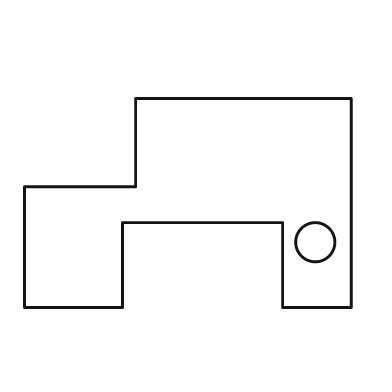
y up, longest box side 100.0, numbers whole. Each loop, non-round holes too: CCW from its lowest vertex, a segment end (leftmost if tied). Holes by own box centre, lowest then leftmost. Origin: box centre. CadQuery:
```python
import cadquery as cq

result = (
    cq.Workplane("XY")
    .moveTo(-50.0, -32.0)
    .lineTo(-20.0, -32.0)
    .lineTo(-20.0, -6.0)
    .lineTo(29.0, -6.0)
    .lineTo(29.0, -32.0)
    .lineTo(50.0, -32.0)
    .lineTo(50.0, 32.0)
    .lineTo(-16.0, 32.0)
    .lineTo(-16.0, 5.0)
    .lineTo(-50.0, 5.0)
    .close()
    .moveTo(39.0, -12.0)
    .circle(6.0)
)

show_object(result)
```